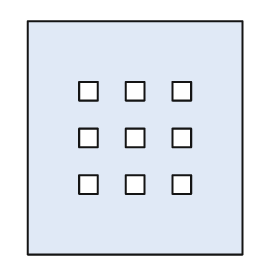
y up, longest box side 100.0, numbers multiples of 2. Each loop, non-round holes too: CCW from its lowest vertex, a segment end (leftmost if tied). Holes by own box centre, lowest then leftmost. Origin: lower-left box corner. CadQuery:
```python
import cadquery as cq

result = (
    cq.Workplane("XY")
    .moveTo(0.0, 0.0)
    .lineTo(92.0, 0.0)
    .lineTo(92.0, 100.0)
    .lineTo(0.0, 100.0)
    .close()
    .moveTo(22.0, 26.0)
    .lineTo(30.0, 26.0)
    .lineTo(30.0, 34.0)
    .lineTo(22.0, 34.0)
    .close()
    .moveTo(42.0, 26.0)
    .lineTo(50.0, 26.0)
    .lineTo(50.0, 34.0)
    .lineTo(42.0, 34.0)
    .close()
    .moveTo(62.0, 26.0)
    .lineTo(70.0, 26.0)
    .lineTo(70.0, 34.0)
    .lineTo(62.0, 34.0)
    .close()
    .moveTo(22.0, 46.0)
    .lineTo(30.0, 46.0)
    .lineTo(30.0, 54.0)
    .lineTo(22.0, 54.0)
    .close()
    .moveTo(42.0, 46.0)
    .lineTo(50.0, 46.0)
    .lineTo(50.0, 54.0)
    .lineTo(42.0, 54.0)
    .close()
    .moveTo(62.0, 46.0)
    .lineTo(70.0, 46.0)
    .lineTo(70.0, 54.0)
    .lineTo(62.0, 54.0)
    .close()
    .moveTo(22.0, 66.0)
    .lineTo(30.0, 66.0)
    .lineTo(30.0, 74.0)
    .lineTo(22.0, 74.0)
    .close()
    .moveTo(42.0, 66.0)
    .lineTo(50.0, 66.0)
    .lineTo(50.0, 74.0)
    .lineTo(42.0, 74.0)
    .close()
    .moveTo(62.0, 66.0)
    .lineTo(70.0, 66.0)
    .lineTo(70.0, 74.0)
    .lineTo(62.0, 74.0)
    .close()
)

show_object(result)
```